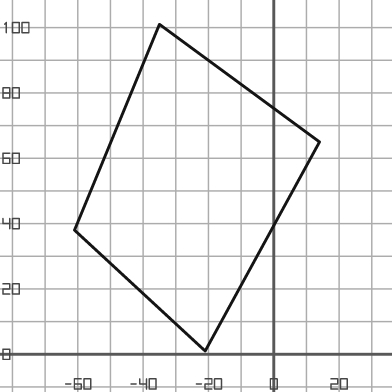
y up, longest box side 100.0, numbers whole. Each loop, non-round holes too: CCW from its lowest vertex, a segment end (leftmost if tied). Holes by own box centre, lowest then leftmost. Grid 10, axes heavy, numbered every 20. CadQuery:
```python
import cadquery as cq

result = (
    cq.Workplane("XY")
    .moveTo(-21.0, 1.0)
    .lineTo(14.0, 65.0)
    .lineTo(-35.0, 101.0)
    .lineTo(-61.0, 38.0)
    .close()
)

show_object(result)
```